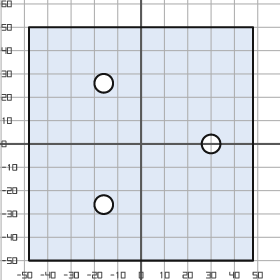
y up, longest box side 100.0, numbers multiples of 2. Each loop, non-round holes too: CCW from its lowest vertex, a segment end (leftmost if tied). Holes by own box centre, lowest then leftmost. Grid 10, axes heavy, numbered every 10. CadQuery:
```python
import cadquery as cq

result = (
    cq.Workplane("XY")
    .moveTo(-48.0, -50.0)
    .lineTo(48.0, -50.0)
    .lineTo(48.0, 50.0)
    .lineTo(-48.0, 50.0)
    .close()
    .moveTo(-16.0, -26.0)
    .circle(4.0)
    .moveTo(30.0, 0.0)
    .circle(4.0)
    .moveTo(-16.0, 26.0)
    .circle(4.0)
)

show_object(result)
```